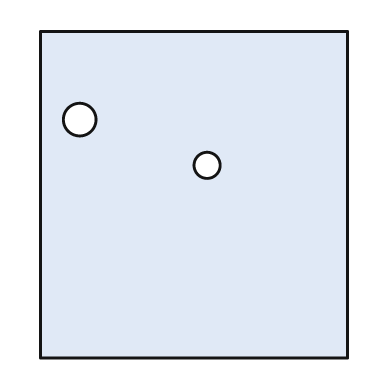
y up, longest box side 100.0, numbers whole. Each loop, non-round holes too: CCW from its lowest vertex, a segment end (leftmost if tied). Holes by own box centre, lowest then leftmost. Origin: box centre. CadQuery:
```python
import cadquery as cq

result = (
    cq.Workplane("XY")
    .moveTo(-47.0, -50.0)
    .lineTo(47.0, -50.0)
    .lineTo(47.0, 50.0)
    .lineTo(-47.0, 50.0)
    .close()
    .moveTo(4.0, 9.0)
    .circle(4.0)
    .moveTo(-35.0, 23.0)
    .circle(5.0)
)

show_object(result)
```